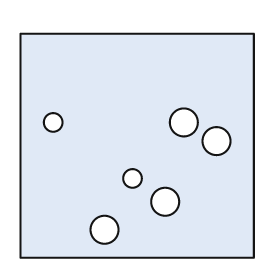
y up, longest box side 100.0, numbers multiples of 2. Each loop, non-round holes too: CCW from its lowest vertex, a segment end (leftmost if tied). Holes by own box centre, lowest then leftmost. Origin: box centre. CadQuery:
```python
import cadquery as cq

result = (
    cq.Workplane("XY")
    .moveTo(-50.0, -48.0)
    .lineTo(50.0, -48.0)
    .lineTo(50.0, 48.0)
    .lineTo(-50.0, 48.0)
    .close()
    .moveTo(-14.0, -36.0)
    .circle(6.0)
    .moveTo(12.0, -24.0)
    .circle(6.0)
    .moveTo(-2.0, -14.0)
    .circle(4.0)
    .moveTo(34.0, 2.0)
    .circle(6.0)
    .moveTo(-36.0, 10.0)
    .circle(4.0)
    .moveTo(20.0, 10.0)
    .circle(6.0)
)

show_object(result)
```